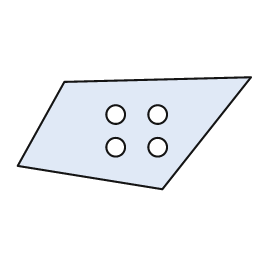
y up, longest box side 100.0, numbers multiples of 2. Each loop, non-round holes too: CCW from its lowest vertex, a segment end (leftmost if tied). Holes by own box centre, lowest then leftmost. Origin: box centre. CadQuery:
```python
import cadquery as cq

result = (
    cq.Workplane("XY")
    .moveTo(12.0, -24.0)
    .lineTo(50.0, 24.0)
    .lineTo(-30.0, 22.0)
    .lineTo(-50.0, -14.0)
    .close()
    .moveTo(-8.0, -6.0)
    .circle(4.0)
    .moveTo(10.0, -6.0)
    .circle(4.0)
    .moveTo(-8.0, 8.0)
    .circle(4.0)
    .moveTo(10.0, 8.0)
    .circle(4.0)
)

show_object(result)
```